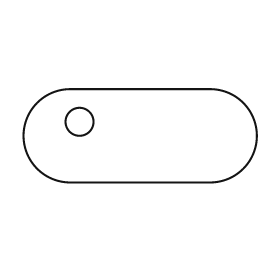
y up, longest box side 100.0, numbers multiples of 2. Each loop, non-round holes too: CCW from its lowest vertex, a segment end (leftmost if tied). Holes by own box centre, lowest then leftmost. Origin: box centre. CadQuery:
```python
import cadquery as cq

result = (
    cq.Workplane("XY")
    .moveTo(-30.0, -20.0)
    .lineTo(30.0, -20.0)
    .threePointArc((50.0, 0.0), (30.0, 20.0))
    .lineTo(-30.0, 20.0)
    .threePointArc((-50.0, 0.0), (-30.0, -20.0))
    .close()
    .moveTo(-26.0, 6.0)
    .circle(6.0)
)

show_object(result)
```